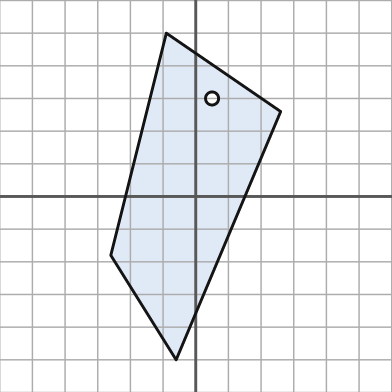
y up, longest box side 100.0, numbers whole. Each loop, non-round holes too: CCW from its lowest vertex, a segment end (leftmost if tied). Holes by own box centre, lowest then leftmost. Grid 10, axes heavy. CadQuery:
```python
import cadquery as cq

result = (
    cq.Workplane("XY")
    .moveTo(-6.0, -50.0)
    .lineTo(26.0, 26.0)
    .lineTo(-9.0, 50.0)
    .lineTo(-26.0, -18.0)
    .close()
    .moveTo(5.0, 30.0)
    .circle(2.0)
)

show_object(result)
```